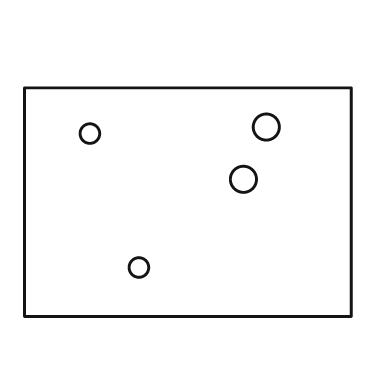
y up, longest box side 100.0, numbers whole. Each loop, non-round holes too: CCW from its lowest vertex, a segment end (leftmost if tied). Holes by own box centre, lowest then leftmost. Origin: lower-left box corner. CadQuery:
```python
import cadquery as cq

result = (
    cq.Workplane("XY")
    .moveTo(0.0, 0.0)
    .lineTo(100.0, 0.0)
    .lineTo(100.0, 70.0)
    .lineTo(0.0, 70.0)
    .close()
    .moveTo(35.0, 15.0)
    .circle(3.0)
    .moveTo(67.0, 42.0)
    .circle(4.0)
    .moveTo(20.0, 56.0)
    .circle(3.0)
    .moveTo(74.0, 58.0)
    .circle(4.0)
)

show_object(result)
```